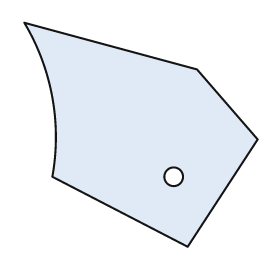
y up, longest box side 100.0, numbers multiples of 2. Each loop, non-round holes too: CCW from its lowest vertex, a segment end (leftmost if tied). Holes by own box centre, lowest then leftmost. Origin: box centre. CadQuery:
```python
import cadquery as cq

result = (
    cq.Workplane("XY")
    .moveTo(20.0, -48.0)
    .lineTo(50.0, -2.0)
    .lineTo(24.0, 28.0)
    .lineTo(-50.0, 48.0)
    .threePointArc((-38.0, 16.0), (-38.0, -18.0))
    .close()
    .moveTo(14.0, -18.0)
    .circle(4.0)
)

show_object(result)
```